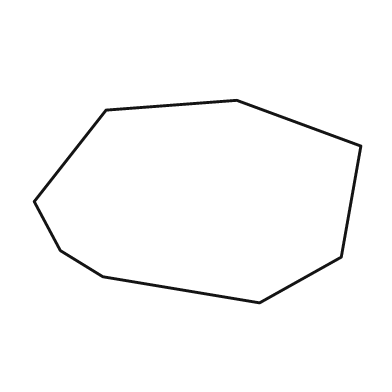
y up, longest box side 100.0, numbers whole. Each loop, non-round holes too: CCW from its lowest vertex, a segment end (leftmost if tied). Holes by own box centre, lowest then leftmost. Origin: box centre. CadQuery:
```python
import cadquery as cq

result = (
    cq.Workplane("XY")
    .moveTo(19.0, -31.0)
    .lineTo(44.0, -17.0)
    .lineTo(50.0, 17.0)
    .lineTo(12.0, 31.0)
    .lineTo(-28.0, 28.0)
    .lineTo(-50.0, 0.0)
    .lineTo(-42.0, -15.0)
    .lineTo(-29.0, -23.0)
    .close()
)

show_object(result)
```